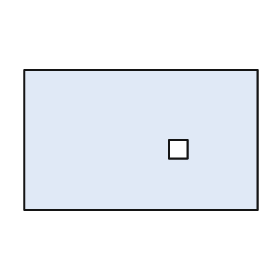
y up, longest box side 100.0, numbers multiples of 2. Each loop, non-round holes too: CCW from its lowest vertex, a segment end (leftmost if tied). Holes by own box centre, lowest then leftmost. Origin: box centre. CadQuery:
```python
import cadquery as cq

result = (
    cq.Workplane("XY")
    .moveTo(-50.0, -30.0)
    .lineTo(50.0, -30.0)
    .lineTo(50.0, 30.0)
    .lineTo(-50.0, 30.0)
    .close()
    .moveTo(12.0, -8.0)
    .lineTo(20.0, -8.0)
    .lineTo(20.0, 0.0)
    .lineTo(12.0, 0.0)
    .close()
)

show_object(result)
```